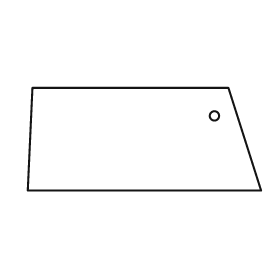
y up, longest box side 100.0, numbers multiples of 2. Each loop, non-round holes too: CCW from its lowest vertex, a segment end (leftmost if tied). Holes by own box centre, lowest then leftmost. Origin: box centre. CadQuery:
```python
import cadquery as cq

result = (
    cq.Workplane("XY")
    .moveTo(-50.0, -22.0)
    .lineTo(50.0, -22.0)
    .lineTo(36.0, 22.0)
    .lineTo(-48.0, 22.0)
    .close()
    .moveTo(30.0, 10.0)
    .circle(2.0)
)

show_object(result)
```